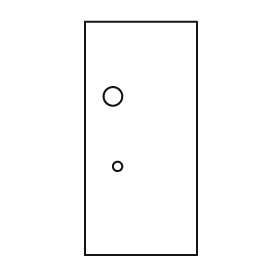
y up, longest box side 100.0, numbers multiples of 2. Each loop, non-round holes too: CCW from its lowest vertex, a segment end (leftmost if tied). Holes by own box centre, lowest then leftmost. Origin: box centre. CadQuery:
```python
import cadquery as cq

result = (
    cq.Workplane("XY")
    .moveTo(-24.0, -50.0)
    .lineTo(24.0, -50.0)
    .lineTo(24.0, 50.0)
    .lineTo(-24.0, 50.0)
    .close()
    .moveTo(-10.0, -12.0)
    .circle(2.0)
    .moveTo(-12.0, 18.0)
    .circle(4.0)
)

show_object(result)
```